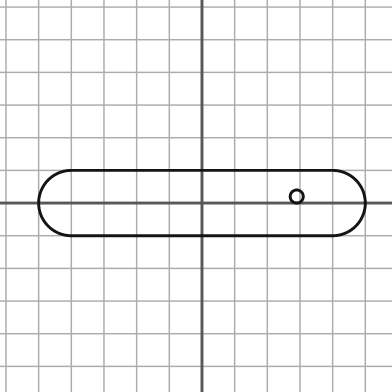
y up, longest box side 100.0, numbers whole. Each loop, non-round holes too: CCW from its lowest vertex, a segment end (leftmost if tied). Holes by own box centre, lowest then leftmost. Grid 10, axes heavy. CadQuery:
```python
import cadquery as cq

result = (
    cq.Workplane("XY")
    .moveTo(-40.0, -10.0)
    .lineTo(40.0, -10.0)
    .threePointArc((50.0, 0.0), (40.0, 10.0))
    .lineTo(-40.0, 10.0)
    .threePointArc((-50.0, 0.0), (-40.0, -10.0))
    .close()
    .moveTo(29.0, 2.0)
    .circle(2.0)
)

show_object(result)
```